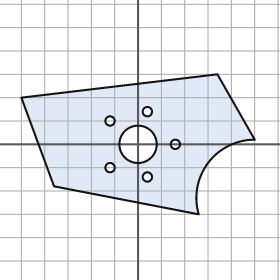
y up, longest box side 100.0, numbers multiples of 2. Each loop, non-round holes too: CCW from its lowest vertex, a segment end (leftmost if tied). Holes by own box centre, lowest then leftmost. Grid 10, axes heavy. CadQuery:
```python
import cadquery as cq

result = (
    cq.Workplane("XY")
    .moveTo(26.0, -30.0)
    .threePointArc((30.0, -8.0), (50.0, 2.0))
    .lineTo(34.0, 30.0)
    .lineTo(-50.0, 20.0)
    .lineTo(-36.0, -18.0)
    .close()
    .moveTo(4.0, -14.0)
    .circle(2.0)
    .moveTo(-12.0, -10.0)
    .circle(2.0)
    .moveTo(0.0, 0.0)
    .circle(8.0)
    .moveTo(16.0, 0.0)
    .circle(2.0)
    .moveTo(-12.0, 10.0)
    .circle(2.0)
    .moveTo(4.0, 14.0)
    .circle(2.0)
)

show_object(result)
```